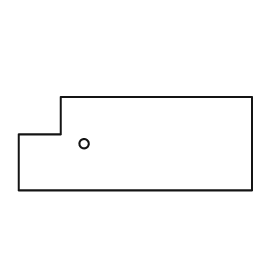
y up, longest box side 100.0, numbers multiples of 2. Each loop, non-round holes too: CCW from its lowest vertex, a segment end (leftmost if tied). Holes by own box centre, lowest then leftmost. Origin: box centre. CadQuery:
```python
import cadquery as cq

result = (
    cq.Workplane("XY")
    .moveTo(-50.0, -20.0)
    .lineTo(50.0, -20.0)
    .lineTo(50.0, 20.0)
    .lineTo(-32.0, 20.0)
    .lineTo(-32.0, 4.0)
    .lineTo(-50.0, 4.0)
    .close()
    .moveTo(-22.0, 0.0)
    .circle(2.0)
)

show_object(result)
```